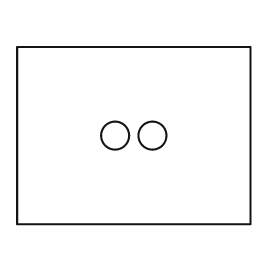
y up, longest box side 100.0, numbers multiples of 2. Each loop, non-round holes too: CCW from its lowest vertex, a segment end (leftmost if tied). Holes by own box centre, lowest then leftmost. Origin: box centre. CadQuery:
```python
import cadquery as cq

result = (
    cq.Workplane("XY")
    .moveTo(-50.0, -38.0)
    .lineTo(50.0, -38.0)
    .lineTo(50.0, 38.0)
    .lineTo(-50.0, 38.0)
    .close()
    .moveTo(-8.0, 0.0)
    .circle(6.0)
    .moveTo(8.0, 0.0)
    .circle(6.0)
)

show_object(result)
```